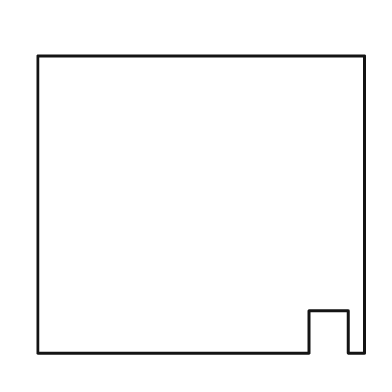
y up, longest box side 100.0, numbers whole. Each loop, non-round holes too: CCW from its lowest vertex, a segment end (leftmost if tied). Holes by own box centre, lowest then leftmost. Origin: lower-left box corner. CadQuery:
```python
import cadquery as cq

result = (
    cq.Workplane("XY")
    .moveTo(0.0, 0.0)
    .lineTo(83.0, 0.0)
    .lineTo(83.0, 13.0)
    .lineTo(95.0, 13.0)
    .lineTo(95.0, 0.0)
    .lineTo(100.0, 0.0)
    .lineTo(100.0, 91.0)
    .lineTo(0.0, 91.0)
    .close()
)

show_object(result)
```